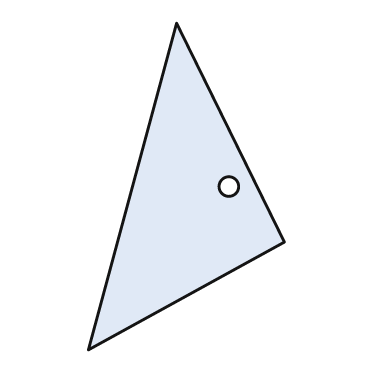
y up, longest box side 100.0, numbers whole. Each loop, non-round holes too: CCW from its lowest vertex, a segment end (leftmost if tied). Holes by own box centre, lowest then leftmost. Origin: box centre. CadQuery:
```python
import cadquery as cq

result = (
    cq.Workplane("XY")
    .moveTo(-30.0, -50.0)
    .lineTo(30.0, -17.0)
    .lineTo(-3.0, 50.0)
    .close()
    .moveTo(13.0, 0.0)
    .circle(3.0)
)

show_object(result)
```